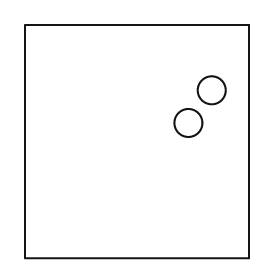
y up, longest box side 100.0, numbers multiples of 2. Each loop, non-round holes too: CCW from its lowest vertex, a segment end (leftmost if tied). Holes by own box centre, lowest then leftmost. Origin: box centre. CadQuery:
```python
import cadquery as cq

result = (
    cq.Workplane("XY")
    .moveTo(-48.0, -50.0)
    .lineTo(48.0, -50.0)
    .lineTo(48.0, 50.0)
    .lineTo(-48.0, 50.0)
    .close()
    .moveTo(22.0, 8.0)
    .circle(6.0)
    .moveTo(32.0, 22.0)
    .circle(6.0)
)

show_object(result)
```